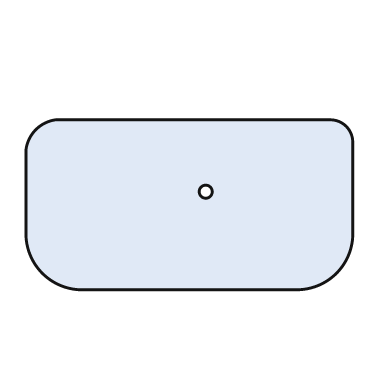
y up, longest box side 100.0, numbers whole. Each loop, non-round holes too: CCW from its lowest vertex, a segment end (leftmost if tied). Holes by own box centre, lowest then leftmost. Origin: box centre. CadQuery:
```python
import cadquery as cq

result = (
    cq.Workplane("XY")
    .moveTo(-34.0, -26.0)
    .lineTo(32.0, -26.0)
    .threePointArc((45.0, -21.0), (50.0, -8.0))
    .lineTo(50.0, 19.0)
    .threePointArc((48.0, 24.0), (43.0, 26.0))
    .lineTo(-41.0, 26.0)
    .threePointArc((-47.0, 23.0), (-50.0, 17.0))
    .lineTo(-50.0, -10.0)
    .threePointArc((-45.0, -21.0), (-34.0, -26.0))
    .close()
    .moveTo(5.0, 4.0)
    .circle(2.0)
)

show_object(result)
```